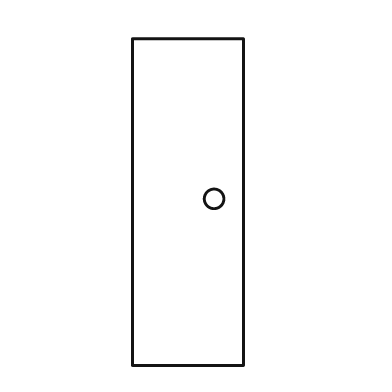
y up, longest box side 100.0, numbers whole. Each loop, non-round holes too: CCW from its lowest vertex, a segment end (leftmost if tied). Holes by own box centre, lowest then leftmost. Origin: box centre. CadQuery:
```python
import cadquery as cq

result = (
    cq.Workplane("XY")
    .moveTo(-17.0, -50.0)
    .lineTo(17.0, -50.0)
    .lineTo(17.0, 50.0)
    .lineTo(-17.0, 50.0)
    .close()
    .moveTo(8.0, 1.0)
    .circle(3.0)
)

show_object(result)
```